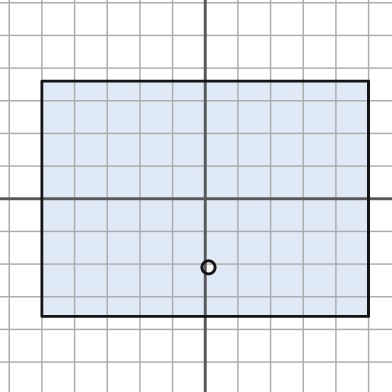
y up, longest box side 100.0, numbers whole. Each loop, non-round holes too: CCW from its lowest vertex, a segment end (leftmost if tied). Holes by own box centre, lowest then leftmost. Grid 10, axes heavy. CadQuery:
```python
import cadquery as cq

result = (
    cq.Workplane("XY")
    .moveTo(-50.0, -36.0)
    .lineTo(50.0, -36.0)
    .lineTo(50.0, 36.0)
    .lineTo(-50.0, 36.0)
    .close()
    .moveTo(1.0, -21.0)
    .circle(2.0)
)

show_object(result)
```